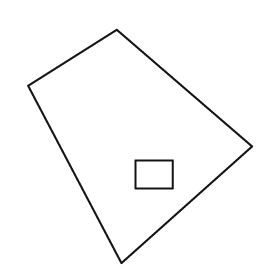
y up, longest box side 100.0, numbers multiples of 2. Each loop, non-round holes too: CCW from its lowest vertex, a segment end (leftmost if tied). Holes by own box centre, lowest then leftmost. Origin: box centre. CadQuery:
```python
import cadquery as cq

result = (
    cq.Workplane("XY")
    .moveTo(-8.0, -50.0)
    .lineTo(48.0, 0.0)
    .lineTo(-10.0, 50.0)
    .lineTo(-48.0, 26.0)
    .close()
    .moveTo(-2.0, -18.0)
    .lineTo(14.0, -18.0)
    .lineTo(14.0, -6.0)
    .lineTo(-2.0, -6.0)
    .close()
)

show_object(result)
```